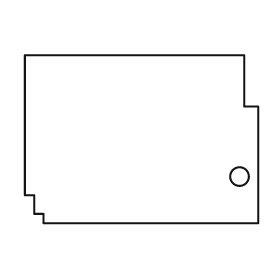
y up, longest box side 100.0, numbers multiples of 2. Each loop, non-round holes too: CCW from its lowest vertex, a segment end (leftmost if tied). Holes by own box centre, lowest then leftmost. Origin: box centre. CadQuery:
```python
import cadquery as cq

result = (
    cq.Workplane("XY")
    .moveTo(-42.0, -36.0)
    .lineTo(50.0, -36.0)
    .lineTo(50.0, 14.0)
    .lineTo(44.0, 14.0)
    .lineTo(44.0, 36.0)
    .lineTo(-50.0, 36.0)
    .lineTo(-50.0, -24.0)
    .lineTo(-46.0, -24.0)
    .lineTo(-46.0, -32.0)
    .lineTo(-42.0, -32.0)
    .close()
    .moveTo(42.0, -16.0)
    .circle(4.0)
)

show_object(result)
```